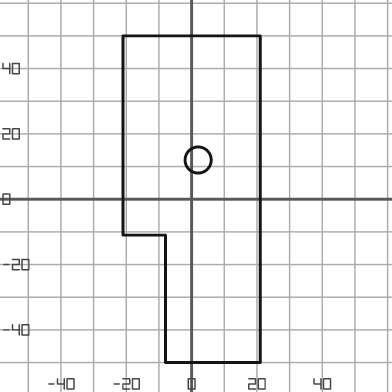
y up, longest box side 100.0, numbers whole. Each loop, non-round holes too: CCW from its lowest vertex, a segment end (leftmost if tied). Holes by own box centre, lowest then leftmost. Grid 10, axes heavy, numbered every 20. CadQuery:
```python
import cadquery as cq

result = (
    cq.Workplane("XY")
    .moveTo(-8.0, -50.0)
    .lineTo(21.0, -50.0)
    .lineTo(21.0, 50.0)
    .lineTo(-21.0, 50.0)
    .lineTo(-21.0, -11.0)
    .lineTo(-8.0, -11.0)
    .close()
    .moveTo(2.0, 12.0)
    .circle(4.0)
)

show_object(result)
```